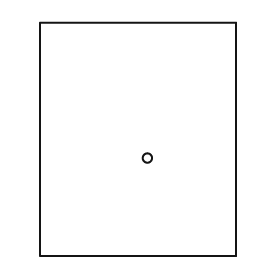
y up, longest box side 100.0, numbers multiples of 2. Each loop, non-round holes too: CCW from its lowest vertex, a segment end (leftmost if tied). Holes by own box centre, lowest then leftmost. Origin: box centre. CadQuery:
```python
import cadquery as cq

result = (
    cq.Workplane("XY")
    .moveTo(-42.0, -50.0)
    .lineTo(42.0, -50.0)
    .lineTo(42.0, 50.0)
    .lineTo(-42.0, 50.0)
    .close()
    .moveTo(4.0, -8.0)
    .circle(2.0)
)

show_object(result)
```